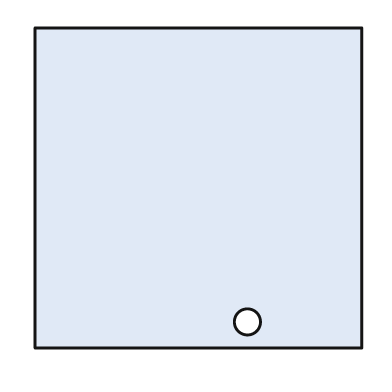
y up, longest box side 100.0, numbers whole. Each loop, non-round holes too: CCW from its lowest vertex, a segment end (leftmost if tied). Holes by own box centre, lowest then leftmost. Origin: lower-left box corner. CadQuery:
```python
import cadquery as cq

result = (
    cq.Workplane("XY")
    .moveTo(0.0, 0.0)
    .lineTo(100.0, 0.0)
    .lineTo(100.0, 98.0)
    .lineTo(0.0, 98.0)
    .close()
    .moveTo(65.0, 8.0)
    .circle(4.0)
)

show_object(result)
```